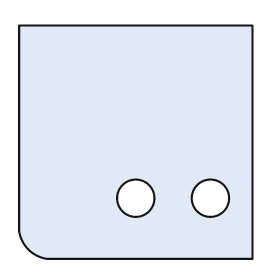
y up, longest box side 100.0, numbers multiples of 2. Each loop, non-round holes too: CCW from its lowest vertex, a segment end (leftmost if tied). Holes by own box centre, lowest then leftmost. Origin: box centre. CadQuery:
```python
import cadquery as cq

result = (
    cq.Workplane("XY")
    .moveTo(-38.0, -50.0)
    .lineTo(50.0, -50.0)
    .lineTo(50.0, 50.0)
    .lineTo(-50.0, 50.0)
    .lineTo(-50.0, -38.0)
    .threePointArc((-46.0, -46.0), (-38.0, -50.0))
    .close()
    .moveTo(0.0, -24.0)
    .circle(8.0)
    .moveTo(32.0, -24.0)
    .circle(8.0)
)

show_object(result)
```